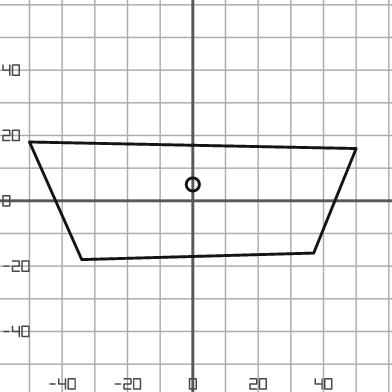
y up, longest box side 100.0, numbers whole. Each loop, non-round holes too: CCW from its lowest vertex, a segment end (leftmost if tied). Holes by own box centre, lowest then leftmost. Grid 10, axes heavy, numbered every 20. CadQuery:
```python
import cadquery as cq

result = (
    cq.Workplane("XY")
    .moveTo(-34.0, -18.0)
    .lineTo(37.0, -16.0)
    .lineTo(50.0, 16.0)
    .lineTo(-50.0, 18.0)
    .close()
    .moveTo(0.0, 5.0)
    .circle(2.0)
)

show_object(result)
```